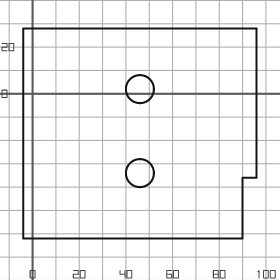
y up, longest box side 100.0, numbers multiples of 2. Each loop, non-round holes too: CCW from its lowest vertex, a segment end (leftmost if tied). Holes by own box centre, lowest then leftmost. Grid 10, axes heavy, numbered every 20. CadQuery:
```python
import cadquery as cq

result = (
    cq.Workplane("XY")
    .moveTo(-4.0, -62.0)
    .lineTo(90.0, -62.0)
    .lineTo(90.0, -36.0)
    .lineTo(96.0, -36.0)
    .lineTo(96.0, 28.0)
    .lineTo(-4.0, 28.0)
    .close()
    .moveTo(46.0, -34.0)
    .circle(6.0)
    .moveTo(46.0, 2.0)
    .circle(6.0)
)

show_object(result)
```